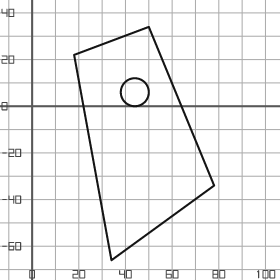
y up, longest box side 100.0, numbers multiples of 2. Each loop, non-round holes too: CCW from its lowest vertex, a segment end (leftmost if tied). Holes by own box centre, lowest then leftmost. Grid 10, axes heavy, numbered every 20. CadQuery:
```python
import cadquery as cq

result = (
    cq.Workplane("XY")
    .moveTo(34.0, -66.0)
    .lineTo(78.0, -34.0)
    .lineTo(50.0, 34.0)
    .lineTo(18.0, 22.0)
    .close()
    .moveTo(44.0, 6.0)
    .circle(6.0)
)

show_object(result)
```